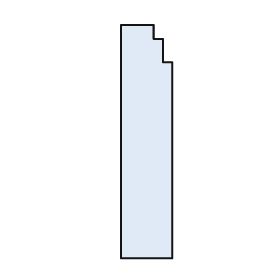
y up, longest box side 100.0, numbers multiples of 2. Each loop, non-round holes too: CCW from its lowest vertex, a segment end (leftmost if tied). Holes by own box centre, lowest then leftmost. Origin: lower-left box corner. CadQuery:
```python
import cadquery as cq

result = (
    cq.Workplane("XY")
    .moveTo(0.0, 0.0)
    .lineTo(22.0, 0.0)
    .lineTo(22.0, 84.0)
    .lineTo(18.0, 84.0)
    .lineTo(18.0, 94.0)
    .lineTo(14.0, 94.0)
    .lineTo(14.0, 100.0)
    .lineTo(0.0, 100.0)
    .close()
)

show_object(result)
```